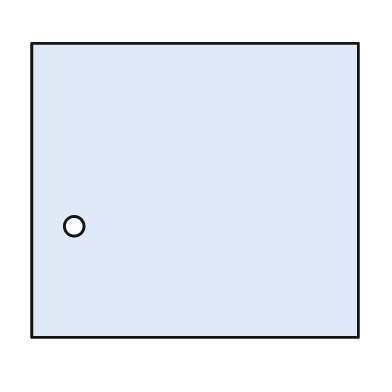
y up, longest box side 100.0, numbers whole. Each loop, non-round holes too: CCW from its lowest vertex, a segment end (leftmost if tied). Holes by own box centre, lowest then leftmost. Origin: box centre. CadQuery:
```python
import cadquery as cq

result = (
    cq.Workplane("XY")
    .moveTo(-50.0, -45.0)
    .lineTo(50.0, -45.0)
    .lineTo(50.0, 45.0)
    .lineTo(-50.0, 45.0)
    .close()
    .moveTo(-37.0, -11.0)
    .circle(3.0)
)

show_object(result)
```